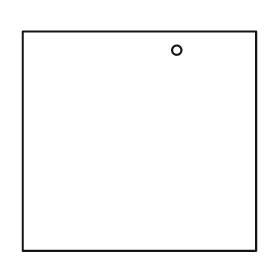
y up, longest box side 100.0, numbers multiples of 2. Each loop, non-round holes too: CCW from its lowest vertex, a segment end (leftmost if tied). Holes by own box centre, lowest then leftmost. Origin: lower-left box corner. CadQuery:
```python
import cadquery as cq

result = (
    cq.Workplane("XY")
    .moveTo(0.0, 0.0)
    .lineTo(100.0, 0.0)
    .lineTo(100.0, 94.0)
    .lineTo(0.0, 94.0)
    .close()
    .moveTo(66.0, 86.0)
    .circle(2.0)
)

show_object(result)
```